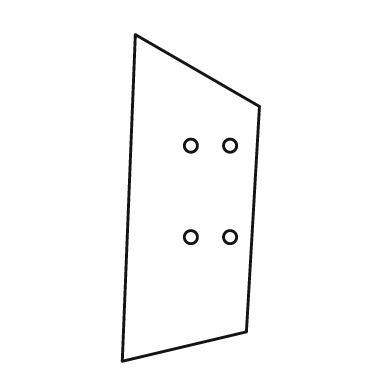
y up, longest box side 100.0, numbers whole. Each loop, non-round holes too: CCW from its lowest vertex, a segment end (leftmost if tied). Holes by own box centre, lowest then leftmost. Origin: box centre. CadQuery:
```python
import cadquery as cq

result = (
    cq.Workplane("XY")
    .moveTo(-21.0, -50.0)
    .lineTo(17.0, -41.0)
    .lineTo(21.0, 28.0)
    .lineTo(-17.0, 50.0)
    .close()
    .moveTo(0.0, -12.0)
    .circle(2.0)
    .moveTo(12.0, -12.0)
    .circle(2.0)
    .moveTo(0.0, 16.0)
    .circle(2.0)
    .moveTo(12.0, 16.0)
    .circle(2.0)
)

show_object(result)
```